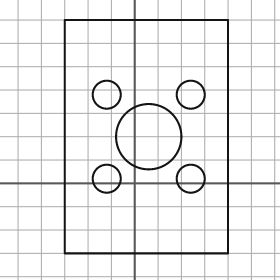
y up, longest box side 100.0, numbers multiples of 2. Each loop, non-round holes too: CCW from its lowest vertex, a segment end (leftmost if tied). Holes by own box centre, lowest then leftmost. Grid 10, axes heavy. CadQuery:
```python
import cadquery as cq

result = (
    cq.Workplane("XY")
    .moveTo(-30.0, -30.0)
    .lineTo(40.0, -30.0)
    .lineTo(40.0, 70.0)
    .lineTo(-30.0, 70.0)
    .close()
    .moveTo(-12.0, 2.0)
    .circle(6.0)
    .moveTo(24.0, 2.0)
    .circle(6.0)
    .moveTo(6.0, 20.0)
    .circle(14.0)
    .moveTo(-12.0, 38.0)
    .circle(6.0)
    .moveTo(24.0, 38.0)
    .circle(6.0)
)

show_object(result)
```